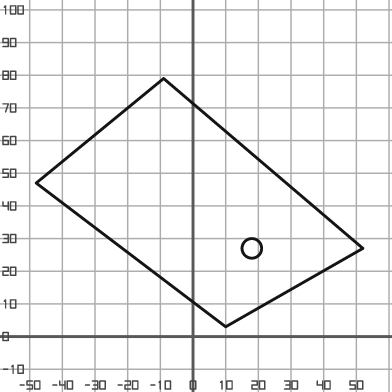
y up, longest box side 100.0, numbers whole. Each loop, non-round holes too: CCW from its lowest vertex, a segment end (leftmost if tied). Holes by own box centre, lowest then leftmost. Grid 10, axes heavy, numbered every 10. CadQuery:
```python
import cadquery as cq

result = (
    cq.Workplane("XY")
    .moveTo(10.0, 3.0)
    .lineTo(52.0, 27.0)
    .lineTo(-9.0, 79.0)
    .lineTo(-48.0, 47.0)
    .close()
    .moveTo(18.0, 27.0)
    .circle(3.0)
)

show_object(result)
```